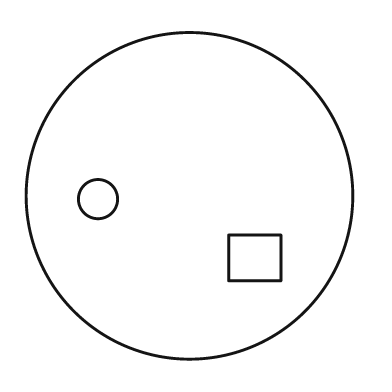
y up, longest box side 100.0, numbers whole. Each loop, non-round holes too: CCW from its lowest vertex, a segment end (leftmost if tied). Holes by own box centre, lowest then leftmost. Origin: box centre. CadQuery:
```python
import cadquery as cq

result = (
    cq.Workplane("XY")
    .moveTo(0.0, 0.0)
    .circle(50.0)
    .moveTo(12.0, -26.0)
    .lineTo(28.0, -26.0)
    .lineTo(28.0, -12.0)
    .lineTo(12.0, -12.0)
    .close()
    .moveTo(-28.0, -1.0)
    .circle(6.0)
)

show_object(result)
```